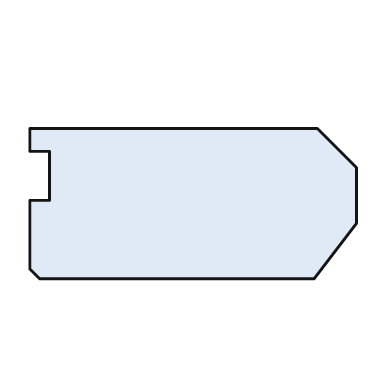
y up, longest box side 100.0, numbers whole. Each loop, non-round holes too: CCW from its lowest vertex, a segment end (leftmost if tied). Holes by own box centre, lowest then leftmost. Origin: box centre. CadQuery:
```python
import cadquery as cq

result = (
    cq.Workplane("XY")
    .moveTo(-47.0, -23.0)
    .lineTo(37.0, -23.0)
    .lineTo(50.0, -6.0)
    .lineTo(50.0, 11.0)
    .lineTo(38.0, 23.0)
    .lineTo(-50.0, 23.0)
    .lineTo(-50.0, 16.0)
    .lineTo(-44.0, 16.0)
    .lineTo(-44.0, 1.0)
    .lineTo(-50.0, 1.0)
    .lineTo(-50.0, -20.0)
    .close()
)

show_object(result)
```